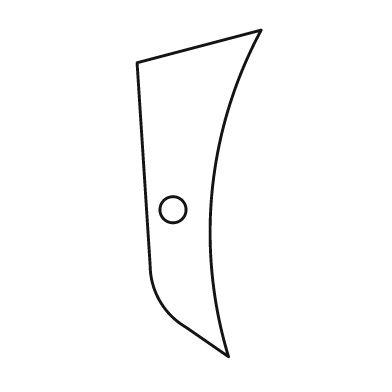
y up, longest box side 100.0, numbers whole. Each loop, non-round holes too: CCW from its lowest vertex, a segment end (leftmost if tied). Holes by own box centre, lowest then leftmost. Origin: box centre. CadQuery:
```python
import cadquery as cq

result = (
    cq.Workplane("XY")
    .moveTo(9.0, -50.0)
    .threePointArc((4.0, 1.0), (19.0, 50.0))
    .lineTo(-19.0, 40.0)
    .lineTo(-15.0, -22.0)
    .threePointArc((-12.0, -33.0), (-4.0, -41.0))
    .close()
    .moveTo(-8.0, -5.0)
    .circle(4.0)
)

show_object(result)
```